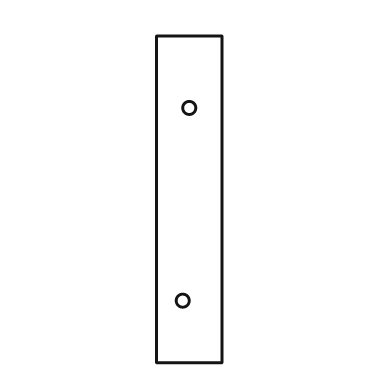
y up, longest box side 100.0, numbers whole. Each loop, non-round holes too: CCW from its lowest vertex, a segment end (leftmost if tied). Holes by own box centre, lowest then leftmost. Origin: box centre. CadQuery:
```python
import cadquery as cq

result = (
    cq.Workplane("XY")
    .moveTo(-10.0, -50.0)
    .lineTo(10.0, -50.0)
    .lineTo(10.0, 50.0)
    .lineTo(-10.0, 50.0)
    .close()
    .moveTo(-2.0, -31.0)
    .circle(2.0)
    .moveTo(0.0, 28.0)
    .circle(2.0)
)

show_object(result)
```